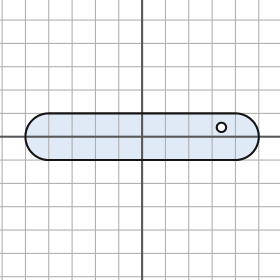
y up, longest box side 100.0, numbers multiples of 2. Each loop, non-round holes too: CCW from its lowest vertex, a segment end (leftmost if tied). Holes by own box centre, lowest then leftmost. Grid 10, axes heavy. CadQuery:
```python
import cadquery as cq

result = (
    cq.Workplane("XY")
    .moveTo(-40.0, -10.0)
    .lineTo(40.0, -10.0)
    .threePointArc((50.0, 0.0), (40.0, 10.0))
    .lineTo(-40.0, 10.0)
    .threePointArc((-50.0, 0.0), (-40.0, -10.0))
    .close()
    .moveTo(34.0, 4.0)
    .circle(2.0)
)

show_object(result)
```